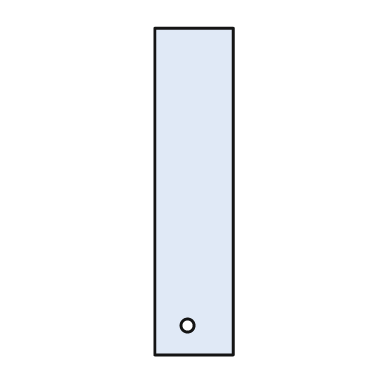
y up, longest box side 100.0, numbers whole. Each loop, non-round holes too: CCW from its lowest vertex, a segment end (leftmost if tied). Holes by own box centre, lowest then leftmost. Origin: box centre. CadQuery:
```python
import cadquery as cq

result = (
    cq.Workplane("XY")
    .moveTo(-12.0, -50.0)
    .lineTo(12.0, -50.0)
    .lineTo(12.0, 50.0)
    .lineTo(-12.0, 50.0)
    .close()
    .moveTo(-2.0, -41.0)
    .circle(2.0)
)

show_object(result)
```